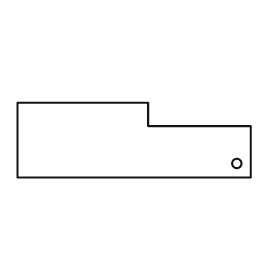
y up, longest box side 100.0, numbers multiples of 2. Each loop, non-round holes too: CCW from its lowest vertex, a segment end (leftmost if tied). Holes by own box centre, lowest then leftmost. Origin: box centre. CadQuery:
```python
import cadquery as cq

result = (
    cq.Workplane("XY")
    .moveTo(-50.0, -16.0)
    .lineTo(50.0, -16.0)
    .lineTo(50.0, 6.0)
    .lineTo(6.0, 6.0)
    .lineTo(6.0, 16.0)
    .lineTo(-50.0, 16.0)
    .close()
    .moveTo(44.0, -10.0)
    .circle(2.0)
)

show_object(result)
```